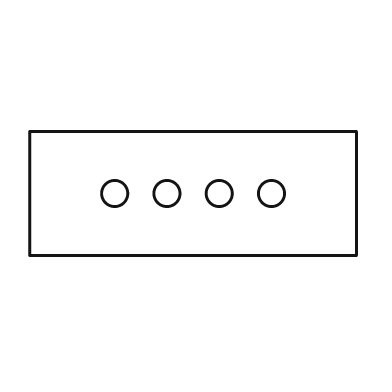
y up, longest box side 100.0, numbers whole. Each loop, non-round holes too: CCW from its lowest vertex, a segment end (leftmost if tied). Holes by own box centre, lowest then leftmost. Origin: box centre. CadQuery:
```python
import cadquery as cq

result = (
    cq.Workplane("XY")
    .moveTo(-50.0, -19.0)
    .lineTo(50.0, -19.0)
    .lineTo(50.0, 19.0)
    .lineTo(-50.0, 19.0)
    .close()
    .moveTo(-24.0, 0.0)
    .circle(4.0)
    .moveTo(-8.0, 0.0)
    .circle(4.0)
    .moveTo(8.0, 0.0)
    .circle(4.0)
    .moveTo(24.0, 0.0)
    .circle(4.0)
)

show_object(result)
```